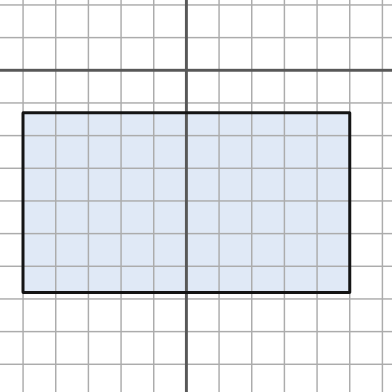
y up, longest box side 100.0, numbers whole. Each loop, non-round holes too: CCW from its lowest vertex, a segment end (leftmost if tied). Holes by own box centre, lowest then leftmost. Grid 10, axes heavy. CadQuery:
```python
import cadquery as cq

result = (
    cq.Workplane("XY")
    .moveTo(-50.0, -68.0)
    .lineTo(50.0, -68.0)
    .lineTo(50.0, -13.0)
    .lineTo(-50.0, -13.0)
    .close()
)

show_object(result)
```